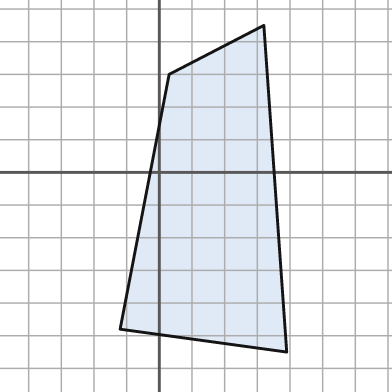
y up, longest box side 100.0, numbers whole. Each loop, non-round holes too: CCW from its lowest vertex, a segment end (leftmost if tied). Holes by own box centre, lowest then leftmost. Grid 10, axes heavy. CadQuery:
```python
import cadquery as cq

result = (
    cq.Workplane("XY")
    .moveTo(39.0, -55.0)
    .lineTo(32.0, 45.0)
    .lineTo(3.0, 30.0)
    .lineTo(-12.0, -48.0)
    .close()
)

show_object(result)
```